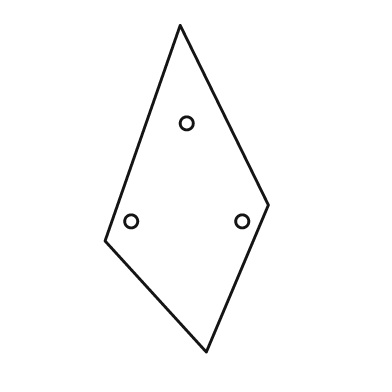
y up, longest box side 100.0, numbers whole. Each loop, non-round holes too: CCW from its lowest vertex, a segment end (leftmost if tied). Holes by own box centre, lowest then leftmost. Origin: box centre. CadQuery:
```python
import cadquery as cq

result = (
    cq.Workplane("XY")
    .moveTo(6.0, -50.0)
    .lineTo(25.0, -5.0)
    .lineTo(-2.0, 50.0)
    .lineTo(-25.0, -16.0)
    .close()
    .moveTo(-17.0, -10.0)
    .circle(2.0)
    .moveTo(17.0, -10.0)
    .circle(2.0)
    .moveTo(0.0, 20.0)
    .circle(2.0)
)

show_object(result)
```